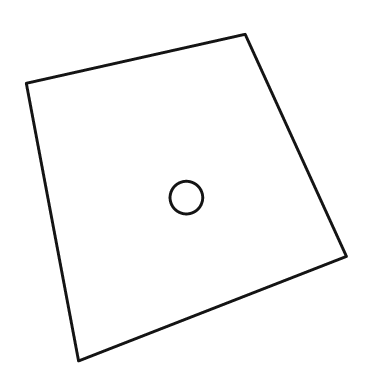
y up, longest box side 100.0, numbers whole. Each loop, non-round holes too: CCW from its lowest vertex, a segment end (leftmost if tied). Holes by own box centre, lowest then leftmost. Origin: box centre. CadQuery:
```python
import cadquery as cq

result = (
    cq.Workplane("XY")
    .moveTo(-33.0, -50.0)
    .lineTo(49.0, -18.0)
    .lineTo(18.0, 50.0)
    .lineTo(-49.0, 35.0)
    .close()
    .moveTo(0.0, 0.0)
    .circle(5.0)
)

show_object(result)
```